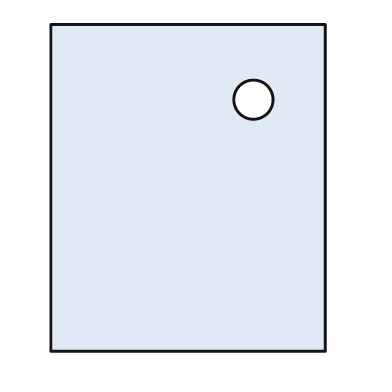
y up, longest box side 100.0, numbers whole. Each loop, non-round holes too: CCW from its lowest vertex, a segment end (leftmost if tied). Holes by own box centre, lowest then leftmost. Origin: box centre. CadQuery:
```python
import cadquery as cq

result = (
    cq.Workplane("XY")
    .moveTo(-42.0, -50.0)
    .lineTo(42.0, -50.0)
    .lineTo(42.0, 50.0)
    .lineTo(-42.0, 50.0)
    .close()
    .moveTo(20.0, 27.0)
    .circle(6.0)
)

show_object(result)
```